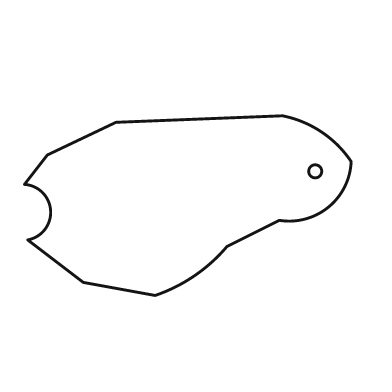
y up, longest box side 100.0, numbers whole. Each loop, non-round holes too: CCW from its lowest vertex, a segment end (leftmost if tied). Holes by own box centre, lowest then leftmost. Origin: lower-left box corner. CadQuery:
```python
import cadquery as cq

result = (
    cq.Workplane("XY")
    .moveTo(40.0, 0.0)
    .threePointArc((52.0, 6.0), (62.0, 15.0))
    .lineTo(78.0, 23.0)
    .threePointArc((93.0, 27.0), (100.0, 41.0))
    .threePointArc((91.0, 50.0), (79.0, 55.0))
    .lineTo(28.0, 53.0)
    .lineTo(7.0, 43.0)
    .lineTo(0.0, 34.0)
    .threePointArc((8.0, 26.0), (1.0, 17.0))
    .lineTo(18.0, 4.0)
    .close()
    .moveTo(89.0, 38.0)
    .circle(2.0)
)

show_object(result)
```